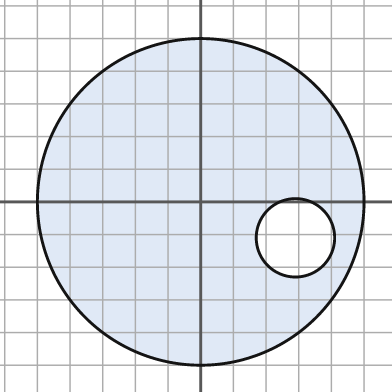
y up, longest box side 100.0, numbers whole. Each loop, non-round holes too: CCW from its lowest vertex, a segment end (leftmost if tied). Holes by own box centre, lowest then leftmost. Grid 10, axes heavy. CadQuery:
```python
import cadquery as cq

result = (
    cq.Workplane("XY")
    .moveTo(0.0, 0.0)
    .circle(50.0)
    .moveTo(29.0, -11.0)
    .circle(12.0)
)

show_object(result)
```